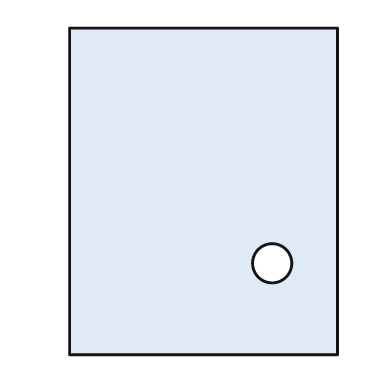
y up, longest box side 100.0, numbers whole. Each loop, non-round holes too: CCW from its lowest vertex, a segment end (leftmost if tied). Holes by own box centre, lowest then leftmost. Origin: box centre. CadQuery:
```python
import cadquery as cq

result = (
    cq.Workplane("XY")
    .moveTo(-41.0, -50.0)
    .lineTo(41.0, -50.0)
    .lineTo(41.0, 50.0)
    .lineTo(-41.0, 50.0)
    .close()
    .moveTo(21.0, -22.0)
    .circle(6.0)
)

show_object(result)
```